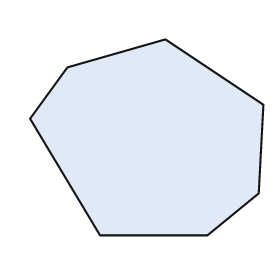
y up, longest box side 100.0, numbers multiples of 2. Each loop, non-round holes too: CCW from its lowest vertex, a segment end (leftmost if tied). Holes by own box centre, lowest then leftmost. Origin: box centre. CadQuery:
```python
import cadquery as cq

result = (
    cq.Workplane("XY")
    .moveTo(-20.0, -42.0)
    .lineTo(26.0, -42.0)
    .lineTo(48.0, -24.0)
    .lineTo(50.0, 14.0)
    .lineTo(8.0, 42.0)
    .lineTo(-34.0, 30.0)
    .lineTo(-50.0, 8.0)
    .close()
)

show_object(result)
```